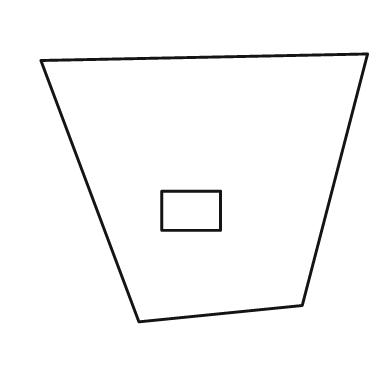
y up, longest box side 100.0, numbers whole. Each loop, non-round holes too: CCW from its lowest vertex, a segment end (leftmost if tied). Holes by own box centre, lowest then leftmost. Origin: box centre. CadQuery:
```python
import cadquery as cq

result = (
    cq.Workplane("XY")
    .moveTo(-20.0, -41.0)
    .lineTo(30.0, -36.0)
    .lineTo(50.0, 41.0)
    .lineTo(-50.0, 39.0)
    .close()
    .moveTo(-13.0, -13.0)
    .lineTo(5.0, -13.0)
    .lineTo(5.0, -1.0)
    .lineTo(-13.0, -1.0)
    .close()
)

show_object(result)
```